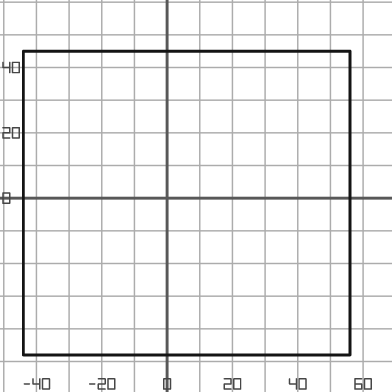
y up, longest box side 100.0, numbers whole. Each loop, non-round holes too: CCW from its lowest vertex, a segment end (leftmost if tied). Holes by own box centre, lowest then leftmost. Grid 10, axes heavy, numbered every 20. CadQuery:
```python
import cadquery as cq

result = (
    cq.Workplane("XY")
    .moveTo(-44.0, -48.0)
    .lineTo(56.0, -48.0)
    .lineTo(56.0, 45.0)
    .lineTo(-44.0, 45.0)
    .close()
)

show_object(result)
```